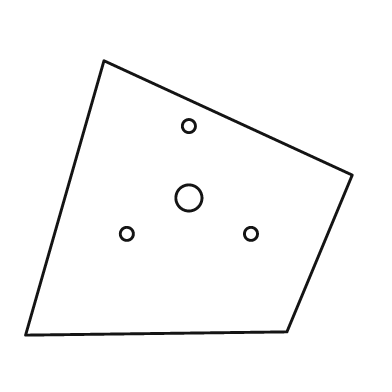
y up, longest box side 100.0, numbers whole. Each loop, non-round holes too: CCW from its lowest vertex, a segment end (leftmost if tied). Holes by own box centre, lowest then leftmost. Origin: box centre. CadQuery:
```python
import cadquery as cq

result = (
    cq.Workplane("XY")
    .moveTo(-50.0, -42.0)
    .lineTo(30.0, -41.0)
    .lineTo(50.0, 7.0)
    .lineTo(-26.0, 42.0)
    .close()
    .moveTo(-19.0, -11.0)
    .circle(2.0)
    .moveTo(19.0, -11.0)
    .circle(2.0)
    .moveTo(0.0, 0.0)
    .circle(4.0)
    .moveTo(0.0, 22.0)
    .circle(2.0)
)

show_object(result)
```